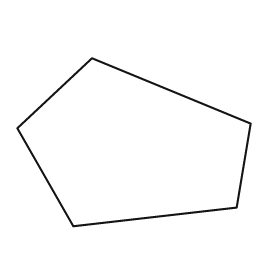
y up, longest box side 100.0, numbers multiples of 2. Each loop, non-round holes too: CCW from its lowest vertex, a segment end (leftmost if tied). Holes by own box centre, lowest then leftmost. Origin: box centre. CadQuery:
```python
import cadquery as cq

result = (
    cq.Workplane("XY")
    .moveTo(-26.0, -36.0)
    .lineTo(44.0, -28.0)
    .lineTo(50.0, 8.0)
    .lineTo(-18.0, 36.0)
    .lineTo(-50.0, 6.0)
    .close()
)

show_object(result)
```